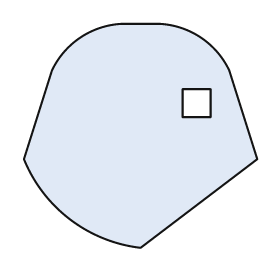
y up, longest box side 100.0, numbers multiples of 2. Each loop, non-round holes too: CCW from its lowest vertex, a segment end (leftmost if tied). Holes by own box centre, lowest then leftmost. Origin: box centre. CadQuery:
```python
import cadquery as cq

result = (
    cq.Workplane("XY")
    .moveTo(0.0, -48.0)
    .lineTo(50.0, -10.0)
    .lineTo(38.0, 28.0)
    .threePointArc((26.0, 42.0), (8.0, 48.0))
    .lineTo(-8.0, 48.0)
    .threePointArc((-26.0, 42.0), (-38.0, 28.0))
    .lineTo(-50.0, -10.0)
    .threePointArc((-30.0, -36.0), (0.0, -48.0))
    .close()
    .moveTo(18.0, 8.0)
    .lineTo(30.0, 8.0)
    .lineTo(30.0, 20.0)
    .lineTo(18.0, 20.0)
    .close()
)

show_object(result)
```